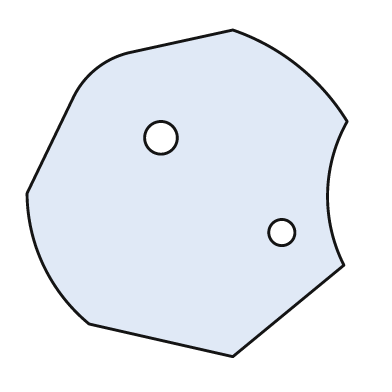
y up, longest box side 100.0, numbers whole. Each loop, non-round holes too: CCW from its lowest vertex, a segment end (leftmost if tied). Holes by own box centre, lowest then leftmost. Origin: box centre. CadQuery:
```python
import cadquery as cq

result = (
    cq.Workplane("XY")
    .moveTo(14.0, -50.0)
    .lineTo(48.0, -22.0)
    .threePointArc((43.0, 0.0), (49.0, 22.0))
    .threePointArc((34.0, 39.0), (14.0, 50.0))
    .lineTo(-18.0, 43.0)
    .threePointArc((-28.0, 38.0), (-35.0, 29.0))
    .lineTo(-49.0, 0.0)
    .threePointArc((-44.0, -22.0), (-30.0, -40.0))
    .close()
    .moveTo(29.0, -12.0)
    .circle(4.0)
    .moveTo(-8.0, 17.0)
    .circle(5.0)
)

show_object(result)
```